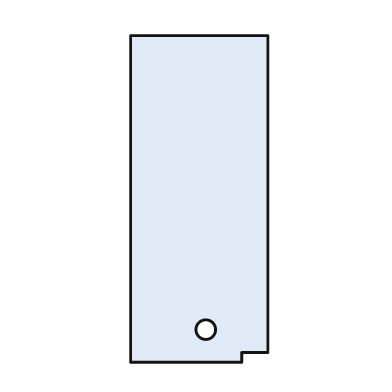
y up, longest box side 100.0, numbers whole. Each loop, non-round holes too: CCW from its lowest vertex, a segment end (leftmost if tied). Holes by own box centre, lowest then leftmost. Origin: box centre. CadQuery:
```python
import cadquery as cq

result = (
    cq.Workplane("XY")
    .moveTo(-21.0, -50.0)
    .lineTo(13.0, -50.0)
    .lineTo(13.0, -47.0)
    .lineTo(21.0, -47.0)
    .lineTo(21.0, 50.0)
    .lineTo(-21.0, 50.0)
    .close()
    .moveTo(2.0, -40.0)
    .circle(3.0)
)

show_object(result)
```